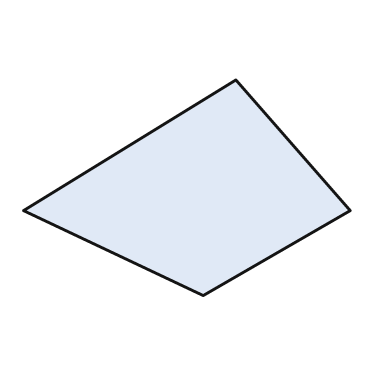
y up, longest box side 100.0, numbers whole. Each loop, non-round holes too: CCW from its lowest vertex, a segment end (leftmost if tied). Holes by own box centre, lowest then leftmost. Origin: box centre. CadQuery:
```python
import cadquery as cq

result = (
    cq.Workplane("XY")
    .moveTo(5.0, -33.0)
    .lineTo(50.0, -7.0)
    .lineTo(15.0, 33.0)
    .lineTo(-50.0, -7.0)
    .close()
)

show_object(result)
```